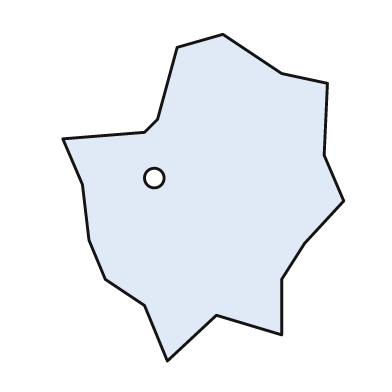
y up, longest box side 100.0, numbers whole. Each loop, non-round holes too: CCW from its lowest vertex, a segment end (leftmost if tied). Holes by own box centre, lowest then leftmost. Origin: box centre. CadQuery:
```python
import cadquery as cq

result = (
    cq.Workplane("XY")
    .moveTo(-11.0, -50.0)
    .lineTo(4.0, -36.0)
    .lineTo(24.0, -42.0)
    .lineTo(24.0, -25.0)
    .lineTo(31.0, -14.0)
    .lineTo(43.0, -1.0)
    .lineTo(37.0, 13.0)
    .lineTo(38.0, 35.0)
    .lineTo(24.0, 38.0)
    .lineTo(6.0, 50.0)
    .lineTo(-8.0, 46.0)
    .lineTo(-14.0, 24.0)
    .lineTo(-18.0, 20.0)
    .lineTo(-43.0, 18.0)
    .lineTo(-37.0, 4.0)
    .lineTo(-35.0, -13.0)
    .lineTo(-30.0, -25.0)
    .lineTo(-18.0, -33.0)
    .close()
    .moveTo(-15.0, 6.0)
    .circle(3.0)
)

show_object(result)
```